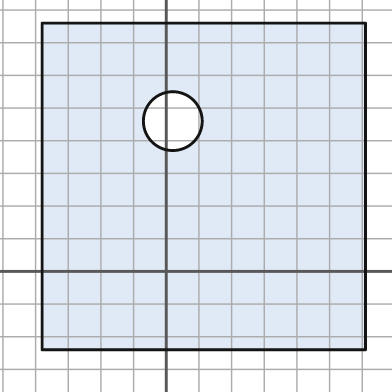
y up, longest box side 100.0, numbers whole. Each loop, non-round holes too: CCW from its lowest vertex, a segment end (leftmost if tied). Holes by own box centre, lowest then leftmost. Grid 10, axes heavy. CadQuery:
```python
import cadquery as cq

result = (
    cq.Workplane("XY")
    .moveTo(-38.0, -24.0)
    .lineTo(61.0, -24.0)
    .lineTo(61.0, 76.0)
    .lineTo(-38.0, 76.0)
    .close()
    .moveTo(2.0, 46.0)
    .circle(9.0)
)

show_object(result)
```